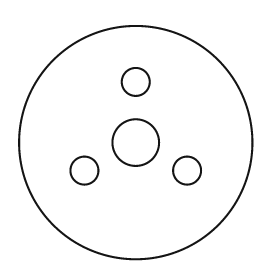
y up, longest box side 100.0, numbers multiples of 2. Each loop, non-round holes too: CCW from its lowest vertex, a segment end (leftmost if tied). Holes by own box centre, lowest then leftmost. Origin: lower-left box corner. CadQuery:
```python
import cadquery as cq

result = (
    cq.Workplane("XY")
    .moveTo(50.0, 50.0)
    .circle(50.0)
    .moveTo(28.0, 38.0)
    .circle(6.0)
    .moveTo(72.0, 38.0)
    .circle(6.0)
    .moveTo(50.0, 50.0)
    .circle(10.0)
    .moveTo(50.0, 76.0)
    .circle(6.0)
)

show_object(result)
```